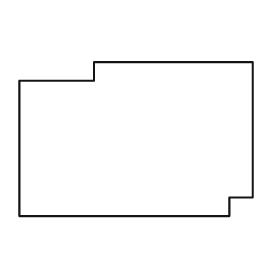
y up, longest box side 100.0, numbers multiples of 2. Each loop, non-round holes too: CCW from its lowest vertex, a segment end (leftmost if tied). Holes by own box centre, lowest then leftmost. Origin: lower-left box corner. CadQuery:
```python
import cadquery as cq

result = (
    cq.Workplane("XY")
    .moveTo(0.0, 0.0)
    .lineTo(90.0, 0.0)
    .lineTo(90.0, 8.0)
    .lineTo(100.0, 8.0)
    .lineTo(100.0, 66.0)
    .lineTo(32.0, 66.0)
    .lineTo(32.0, 58.0)
    .lineTo(0.0, 58.0)
    .close()
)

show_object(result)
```